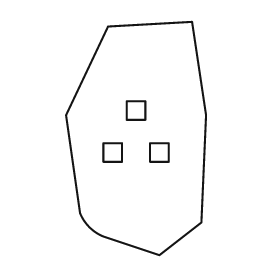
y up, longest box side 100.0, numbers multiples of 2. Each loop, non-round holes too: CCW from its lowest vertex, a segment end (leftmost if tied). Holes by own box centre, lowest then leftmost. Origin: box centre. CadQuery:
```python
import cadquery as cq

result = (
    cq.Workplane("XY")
    .moveTo(10.0, -50.0)
    .lineTo(28.0, -36.0)
    .lineTo(30.0, 10.0)
    .lineTo(24.0, 50.0)
    .lineTo(-12.0, 48.0)
    .lineTo(-30.0, 10.0)
    .lineTo(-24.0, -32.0)
    .threePointArc((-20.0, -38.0), (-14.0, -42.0))
    .close()
    .moveTo(-14.0, -10.0)
    .lineTo(-6.0, -10.0)
    .lineTo(-6.0, -2.0)
    .lineTo(-14.0, -2.0)
    .close()
    .moveTo(6.0, -10.0)
    .lineTo(14.0, -10.0)
    .lineTo(14.0, -2.0)
    .lineTo(6.0, -2.0)
    .close()
    .moveTo(-4.0, 8.0)
    .lineTo(4.0, 8.0)
    .lineTo(4.0, 16.0)
    .lineTo(-4.0, 16.0)
    .close()
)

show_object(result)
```